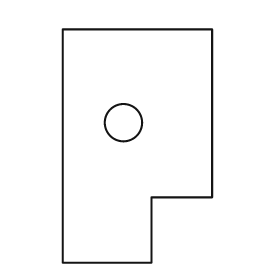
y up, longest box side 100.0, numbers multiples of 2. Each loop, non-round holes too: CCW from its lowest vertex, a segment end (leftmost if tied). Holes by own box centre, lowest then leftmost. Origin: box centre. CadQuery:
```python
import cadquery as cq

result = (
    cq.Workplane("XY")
    .moveTo(-32.0, -50.0)
    .lineTo(6.0, -50.0)
    .lineTo(6.0, -22.0)
    .lineTo(32.0, -22.0)
    .lineTo(32.0, 50.0)
    .lineTo(-32.0, 50.0)
    .close()
    .moveTo(-6.0, 10.0)
    .circle(8.0)
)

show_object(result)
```